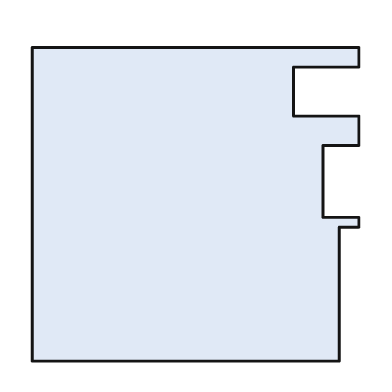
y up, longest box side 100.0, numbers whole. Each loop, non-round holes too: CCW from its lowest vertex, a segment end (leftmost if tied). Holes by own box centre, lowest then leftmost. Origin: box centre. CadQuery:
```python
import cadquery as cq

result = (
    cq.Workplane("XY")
    .moveTo(-50.0, -48.0)
    .lineTo(44.0, -48.0)
    .lineTo(44.0, -7.0)
    .lineTo(50.0, -7.0)
    .lineTo(50.0, -4.0)
    .lineTo(39.0, -4.0)
    .lineTo(39.0, 18.0)
    .lineTo(50.0, 18.0)
    .lineTo(50.0, 27.0)
    .lineTo(30.0, 27.0)
    .lineTo(30.0, 42.0)
    .lineTo(50.0, 42.0)
    .lineTo(50.0, 48.0)
    .lineTo(-50.0, 48.0)
    .close()
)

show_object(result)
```